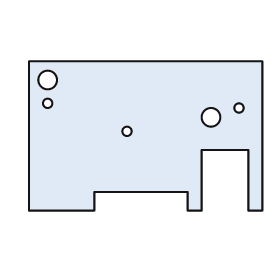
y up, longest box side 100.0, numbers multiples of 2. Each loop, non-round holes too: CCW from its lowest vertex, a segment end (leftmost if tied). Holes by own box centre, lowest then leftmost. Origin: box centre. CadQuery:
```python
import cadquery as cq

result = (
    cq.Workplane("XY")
    .moveTo(-50.0, -32.0)
    .lineTo(-22.0, -32.0)
    .lineTo(-22.0, -24.0)
    .lineTo(18.0, -24.0)
    .lineTo(18.0, -32.0)
    .lineTo(24.0, -32.0)
    .lineTo(24.0, -6.0)
    .lineTo(44.0, -6.0)
    .lineTo(44.0, -32.0)
    .lineTo(50.0, -32.0)
    .lineTo(50.0, 32.0)
    .lineTo(-50.0, 32.0)
    .close()
    .moveTo(-8.0, 2.0)
    .circle(2.0)
    .moveTo(28.0, 8.0)
    .circle(4.0)
    .moveTo(40.0, 12.0)
    .circle(2.0)
    .moveTo(-42.0, 14.0)
    .circle(2.0)
    .moveTo(-42.0, 24.0)
    .circle(4.0)
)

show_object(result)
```